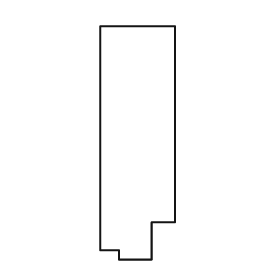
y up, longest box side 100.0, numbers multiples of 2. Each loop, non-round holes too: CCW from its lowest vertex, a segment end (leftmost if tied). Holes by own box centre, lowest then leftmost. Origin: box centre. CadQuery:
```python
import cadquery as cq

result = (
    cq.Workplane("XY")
    .moveTo(-8.0, -50.0)
    .lineTo(6.0, -50.0)
    .lineTo(6.0, -34.0)
    .lineTo(16.0, -34.0)
    .lineTo(16.0, 50.0)
    .lineTo(-16.0, 50.0)
    .lineTo(-16.0, -46.0)
    .lineTo(-8.0, -46.0)
    .close()
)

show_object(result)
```